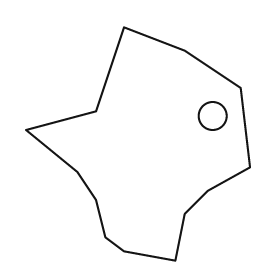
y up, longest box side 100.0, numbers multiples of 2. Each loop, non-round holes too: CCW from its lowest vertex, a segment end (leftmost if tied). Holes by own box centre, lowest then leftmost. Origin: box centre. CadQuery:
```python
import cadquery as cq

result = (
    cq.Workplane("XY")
    .moveTo(16.0, -50.0)
    .lineTo(20.0, -30.0)
    .lineTo(30.0, -20.0)
    .lineTo(48.0, -10.0)
    .lineTo(44.0, 24.0)
    .lineTo(20.0, 40.0)
    .lineTo(-6.0, 50.0)
    .lineTo(-18.0, 14.0)
    .lineTo(-48.0, 6.0)
    .lineTo(-26.0, -12.0)
    .lineTo(-18.0, -24.0)
    .lineTo(-14.0, -40.0)
    .lineTo(-6.0, -46.0)
    .close()
    .moveTo(32.0, 12.0)
    .circle(6.0)
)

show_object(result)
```